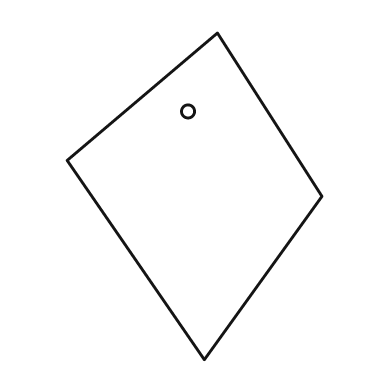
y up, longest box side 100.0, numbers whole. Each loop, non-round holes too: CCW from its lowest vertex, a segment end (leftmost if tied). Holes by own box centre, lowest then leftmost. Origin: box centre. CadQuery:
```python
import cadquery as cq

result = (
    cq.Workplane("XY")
    .moveTo(3.0, -50.0)
    .lineTo(39.0, 0.0)
    .lineTo(7.0, 50.0)
    .lineTo(-39.0, 11.0)
    .close()
    .moveTo(-2.0, 26.0)
    .circle(2.0)
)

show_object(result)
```